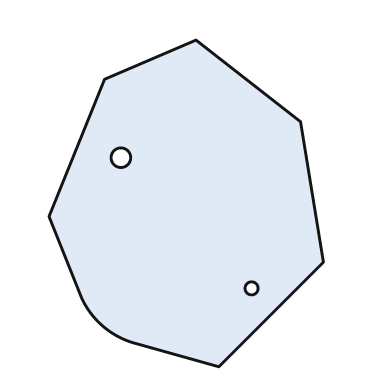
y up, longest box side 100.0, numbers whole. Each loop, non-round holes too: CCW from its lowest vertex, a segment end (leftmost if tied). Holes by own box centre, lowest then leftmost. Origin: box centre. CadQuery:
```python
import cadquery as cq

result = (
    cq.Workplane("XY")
    .moveTo(10.0, -50.0)
    .lineTo(42.0, -18.0)
    .lineTo(35.0, 25.0)
    .lineTo(3.0, 50.0)
    .lineTo(-25.0, 38.0)
    .lineTo(-42.0, -4.0)
    .lineTo(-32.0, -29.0)
    .threePointArc((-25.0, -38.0), (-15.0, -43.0))
    .close()
    .moveTo(20.0, -26.0)
    .circle(2.0)
    .moveTo(-20.0, 14.0)
    .circle(3.0)
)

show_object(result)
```